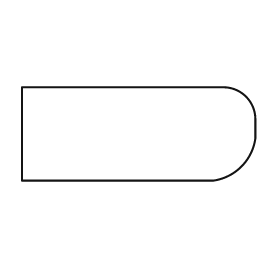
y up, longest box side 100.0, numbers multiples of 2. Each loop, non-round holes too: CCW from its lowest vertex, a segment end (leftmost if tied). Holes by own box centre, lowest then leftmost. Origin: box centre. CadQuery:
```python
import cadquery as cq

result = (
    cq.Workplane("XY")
    .moveTo(-50.0, -20.0)
    .lineTo(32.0, -20.0)
    .threePointArc((44.0, -14.0), (50.0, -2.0))
    .lineTo(50.0, 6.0)
    .threePointArc((46.0, 16.0), (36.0, 20.0))
    .lineTo(-50.0, 20.0)
    .close()
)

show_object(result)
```